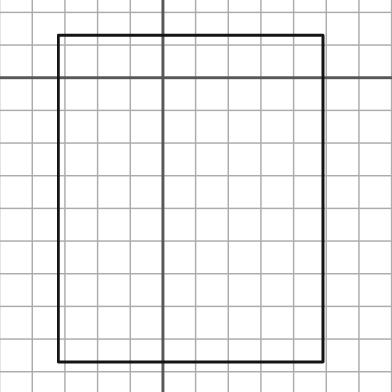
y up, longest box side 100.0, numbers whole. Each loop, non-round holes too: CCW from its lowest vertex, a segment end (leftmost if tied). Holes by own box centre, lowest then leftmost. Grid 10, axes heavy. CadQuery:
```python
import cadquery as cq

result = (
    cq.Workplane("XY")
    .moveTo(-32.0, -87.0)
    .lineTo(49.0, -87.0)
    .lineTo(49.0, 13.0)
    .lineTo(-32.0, 13.0)
    .close()
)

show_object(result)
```